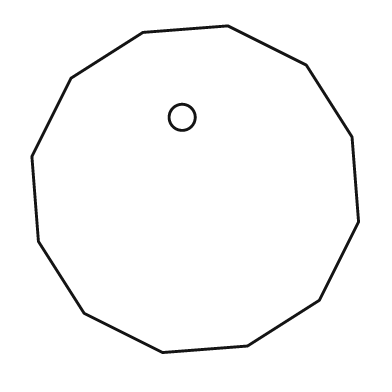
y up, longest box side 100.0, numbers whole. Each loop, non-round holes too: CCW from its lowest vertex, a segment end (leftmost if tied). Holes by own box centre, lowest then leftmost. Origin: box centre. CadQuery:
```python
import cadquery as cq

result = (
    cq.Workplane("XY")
    .moveTo(-10.0, -50.0)
    .lineTo(16.0, -48.0)
    .lineTo(38.0, -34.0)
    .lineTo(50.0, -10.0)
    .lineTo(48.0, 16.0)
    .lineTo(34.0, 38.0)
    .lineTo(10.0, 50.0)
    .lineTo(-16.0, 48.0)
    .lineTo(-38.0, 34.0)
    .lineTo(-50.0, 10.0)
    .lineTo(-48.0, -16.0)
    .lineTo(-34.0, -38.0)
    .close()
    .moveTo(-4.0, 22.0)
    .circle(4.0)
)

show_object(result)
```